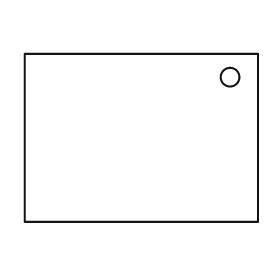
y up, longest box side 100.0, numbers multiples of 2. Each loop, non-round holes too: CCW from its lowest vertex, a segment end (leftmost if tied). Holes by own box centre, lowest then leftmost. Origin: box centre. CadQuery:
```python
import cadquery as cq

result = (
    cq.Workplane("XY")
    .moveTo(-50.0, -36.0)
    .lineTo(50.0, -36.0)
    .lineTo(50.0, 36.0)
    .lineTo(-50.0, 36.0)
    .close()
    .moveTo(38.0, 26.0)
    .circle(4.0)
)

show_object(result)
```